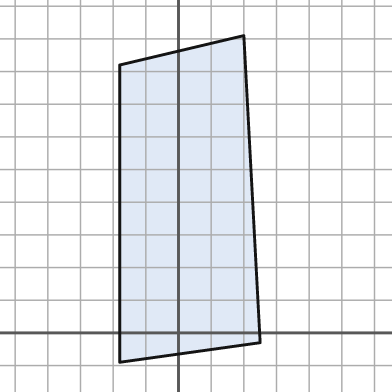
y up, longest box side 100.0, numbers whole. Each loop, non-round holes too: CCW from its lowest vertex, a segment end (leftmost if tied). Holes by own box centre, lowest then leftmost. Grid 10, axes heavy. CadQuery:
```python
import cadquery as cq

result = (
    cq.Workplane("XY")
    .moveTo(-18.0, -9.0)
    .lineTo(25.0, -3.0)
    .lineTo(20.0, 91.0)
    .lineTo(-18.0, 82.0)
    .close()
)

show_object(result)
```